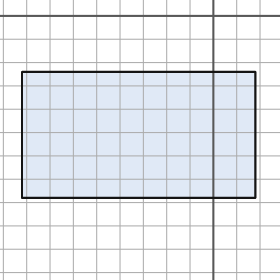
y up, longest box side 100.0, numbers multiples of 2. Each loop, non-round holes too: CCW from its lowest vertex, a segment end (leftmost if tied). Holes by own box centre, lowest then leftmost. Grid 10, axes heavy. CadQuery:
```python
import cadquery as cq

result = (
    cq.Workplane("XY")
    .moveTo(-82.0, -78.0)
    .lineTo(18.0, -78.0)
    .lineTo(18.0, -24.0)
    .lineTo(-82.0, -24.0)
    .close()
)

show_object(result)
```